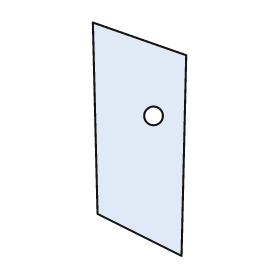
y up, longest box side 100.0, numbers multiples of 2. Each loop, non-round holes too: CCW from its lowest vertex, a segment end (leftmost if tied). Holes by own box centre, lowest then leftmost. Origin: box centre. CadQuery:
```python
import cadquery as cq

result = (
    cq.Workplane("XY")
    .moveTo(18.0, -50.0)
    .lineTo(20.0, 36.0)
    .lineTo(-20.0, 50.0)
    .lineTo(-18.0, -32.0)
    .close()
    .moveTo(6.0, 10.0)
    .circle(4.0)
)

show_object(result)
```